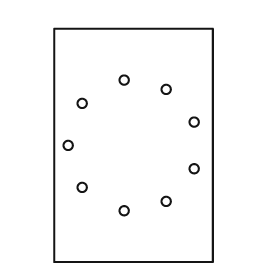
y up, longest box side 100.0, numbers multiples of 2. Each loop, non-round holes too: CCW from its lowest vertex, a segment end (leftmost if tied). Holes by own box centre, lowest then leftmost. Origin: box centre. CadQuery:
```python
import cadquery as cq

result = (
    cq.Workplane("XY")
    .moveTo(-34.0, -50.0)
    .lineTo(34.0, -50.0)
    .lineTo(34.0, 50.0)
    .lineTo(-34.0, 50.0)
    .close()
    .moveTo(-4.0, -28.0)
    .circle(2.0)
    .moveTo(14.0, -24.0)
    .circle(2.0)
    .moveTo(-22.0, -18.0)
    .circle(2.0)
    .moveTo(26.0, -10.0)
    .circle(2.0)
    .moveTo(-28.0, 0.0)
    .circle(2.0)
    .moveTo(26.0, 10.0)
    .circle(2.0)
    .moveTo(-22.0, 18.0)
    .circle(2.0)
    .moveTo(14.0, 24.0)
    .circle(2.0)
    .moveTo(-4.0, 28.0)
    .circle(2.0)
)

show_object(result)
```